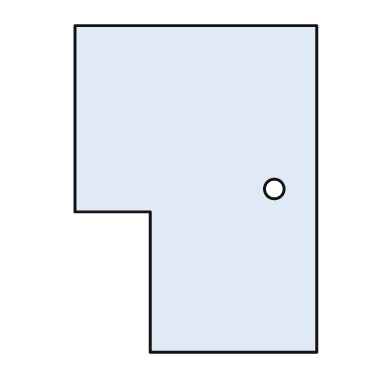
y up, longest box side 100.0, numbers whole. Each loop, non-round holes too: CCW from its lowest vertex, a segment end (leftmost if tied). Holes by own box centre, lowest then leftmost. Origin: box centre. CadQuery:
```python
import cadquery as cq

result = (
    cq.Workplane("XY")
    .moveTo(-14.0, -50.0)
    .lineTo(37.0, -50.0)
    .lineTo(37.0, 50.0)
    .lineTo(-37.0, 50.0)
    .lineTo(-37.0, -7.0)
    .lineTo(-14.0, -7.0)
    .close()
    .moveTo(24.0, 0.0)
    .circle(3.0)
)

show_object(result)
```